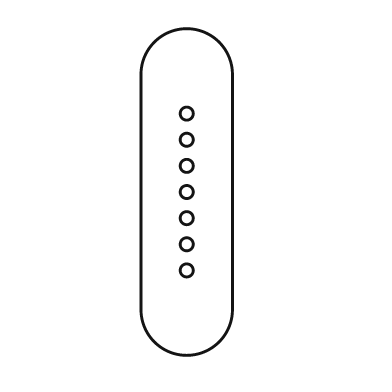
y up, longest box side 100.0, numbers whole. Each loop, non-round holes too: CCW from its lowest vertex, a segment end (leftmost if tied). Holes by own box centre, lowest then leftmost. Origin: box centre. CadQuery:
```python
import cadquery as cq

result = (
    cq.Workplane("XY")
    .moveTo(-14.0, -36.0)
    .threePointArc((0.0, -50.0), (14.0, -36.0))
    .lineTo(14.0, 36.0)
    .threePointArc((0.0, 50.0), (-14.0, 36.0))
    .close()
    .moveTo(0.0, -24.0)
    .circle(2.0)
    .moveTo(0.0, -16.0)
    .circle(2.0)
    .moveTo(0.0, -8.0)
    .circle(2.0)
    .moveTo(0.0, 0.0)
    .circle(2.0)
    .moveTo(0.0, 8.0)
    .circle(2.0)
    .moveTo(0.0, 16.0)
    .circle(2.0)
    .moveTo(0.0, 24.0)
    .circle(2.0)
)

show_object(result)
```